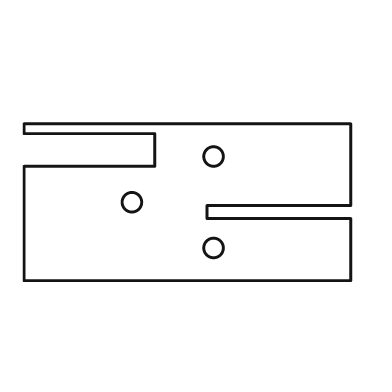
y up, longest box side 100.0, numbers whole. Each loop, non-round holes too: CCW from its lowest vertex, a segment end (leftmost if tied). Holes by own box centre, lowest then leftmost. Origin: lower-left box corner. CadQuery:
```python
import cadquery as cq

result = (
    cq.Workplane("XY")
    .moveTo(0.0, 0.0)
    .lineTo(100.0, 0.0)
    .lineTo(100.0, 19.0)
    .lineTo(56.0, 19.0)
    .lineTo(56.0, 23.0)
    .lineTo(100.0, 23.0)
    .lineTo(100.0, 48.0)
    .lineTo(0.0, 48.0)
    .lineTo(0.0, 45.0)
    .lineTo(40.0, 45.0)
    .lineTo(40.0, 35.0)
    .lineTo(0.0, 35.0)
    .close()
    .moveTo(58.0, 10.0)
    .circle(3.0)
    .moveTo(33.0, 24.0)
    .circle(3.0)
    .moveTo(58.0, 38.0)
    .circle(3.0)
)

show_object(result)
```